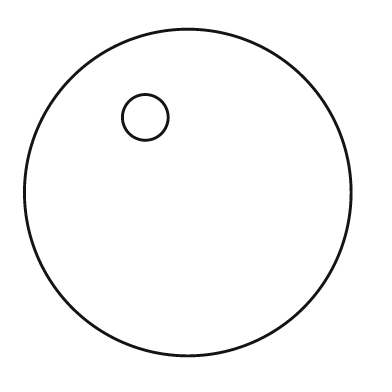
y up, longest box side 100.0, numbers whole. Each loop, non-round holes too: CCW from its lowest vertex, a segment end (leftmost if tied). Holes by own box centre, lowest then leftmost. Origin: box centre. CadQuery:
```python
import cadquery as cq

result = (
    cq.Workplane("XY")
    .moveTo(0.0, 0.0)
    .circle(50.0)
    .moveTo(-13.0, 23.0)
    .circle(7.0)
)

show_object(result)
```